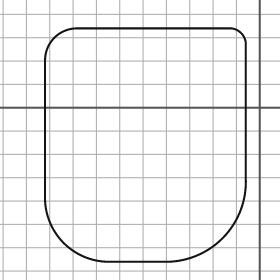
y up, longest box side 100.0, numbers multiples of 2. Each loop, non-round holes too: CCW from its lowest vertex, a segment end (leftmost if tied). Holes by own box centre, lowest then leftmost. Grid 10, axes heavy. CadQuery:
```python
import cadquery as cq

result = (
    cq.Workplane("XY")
    .moveTo(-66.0, -66.0)
    .lineTo(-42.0, -66.0)
    .threePointArc((-16.0, -56.0), (-6.0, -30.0))
    .lineTo(-6.0, 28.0)
    .threePointArc((-8.0, 32.0), (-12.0, 34.0))
    .lineTo(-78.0, 34.0)
    .threePointArc((-88.0, 30.0), (-92.0, 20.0))
    .lineTo(-92.0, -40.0)
    .threePointArc((-84.0, -58.0), (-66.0, -66.0))
    .close()
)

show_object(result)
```